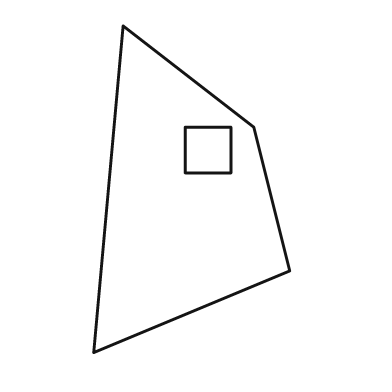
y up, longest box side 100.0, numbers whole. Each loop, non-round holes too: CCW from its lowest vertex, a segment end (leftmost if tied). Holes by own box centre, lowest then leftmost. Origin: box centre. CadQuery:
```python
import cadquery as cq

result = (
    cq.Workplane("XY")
    .moveTo(-30.0, -50.0)
    .lineTo(30.0, -25.0)
    .lineTo(19.0, 19.0)
    .lineTo(-21.0, 50.0)
    .close()
    .moveTo(-2.0, 5.0)
    .lineTo(12.0, 5.0)
    .lineTo(12.0, 19.0)
    .lineTo(-2.0, 19.0)
    .close()
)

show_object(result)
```